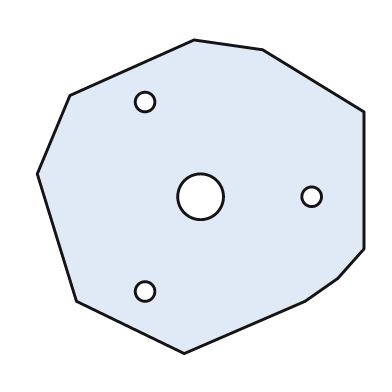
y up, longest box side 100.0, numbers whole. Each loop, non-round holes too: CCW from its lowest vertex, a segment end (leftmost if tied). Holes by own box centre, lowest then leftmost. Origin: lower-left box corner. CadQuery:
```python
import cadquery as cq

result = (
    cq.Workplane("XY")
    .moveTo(45.0, 0.0)
    .lineTo(82.0, 16.0)
    .lineTo(92.0, 23.0)
    .lineTo(100.0, 32.0)
    .lineTo(100.0, 74.0)
    .lineTo(69.0, 93.0)
    .lineTo(48.0, 96.0)
    .lineTo(10.0, 79.0)
    .lineTo(0.0, 55.0)
    .lineTo(12.0, 16.0)
    .close()
    .moveTo(33.0, 19.0)
    .circle(3.0)
    .moveTo(50.0, 48.0)
    .circle(7.0)
    .moveTo(84.0, 48.0)
    .circle(3.0)
    .moveTo(33.0, 77.0)
    .circle(3.0)
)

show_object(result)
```